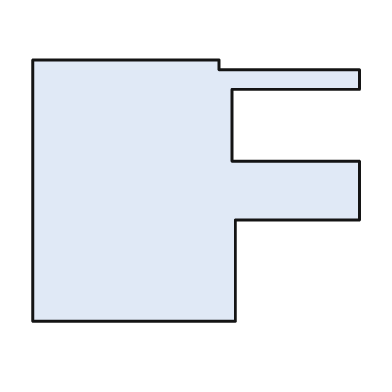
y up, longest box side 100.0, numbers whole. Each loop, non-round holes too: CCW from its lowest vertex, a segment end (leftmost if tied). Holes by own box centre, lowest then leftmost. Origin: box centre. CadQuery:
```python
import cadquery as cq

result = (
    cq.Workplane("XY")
    .moveTo(-50.0, -40.0)
    .lineTo(12.0, -40.0)
    .lineTo(12.0, -9.0)
    .lineTo(50.0, -9.0)
    .lineTo(50.0, 9.0)
    .lineTo(11.0, 9.0)
    .lineTo(11.0, 31.0)
    .lineTo(50.0, 31.0)
    .lineTo(50.0, 37.0)
    .lineTo(7.0, 37.0)
    .lineTo(7.0, 40.0)
    .lineTo(-50.0, 40.0)
    .close()
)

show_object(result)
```